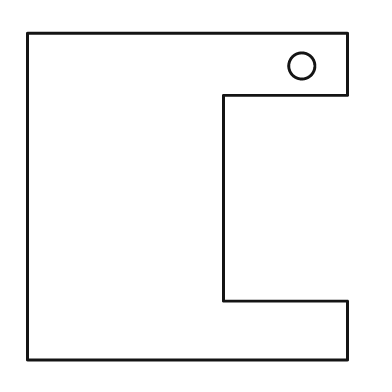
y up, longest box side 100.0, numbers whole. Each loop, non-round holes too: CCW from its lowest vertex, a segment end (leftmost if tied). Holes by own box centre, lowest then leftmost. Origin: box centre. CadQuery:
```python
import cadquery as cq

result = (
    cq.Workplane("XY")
    .moveTo(-49.0, -50.0)
    .lineTo(49.0, -50.0)
    .lineTo(49.0, -32.0)
    .lineTo(11.0, -32.0)
    .lineTo(11.0, 31.0)
    .lineTo(49.0, 31.0)
    .lineTo(49.0, 50.0)
    .lineTo(-49.0, 50.0)
    .close()
    .moveTo(35.0, 40.0)
    .circle(4.0)
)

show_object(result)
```